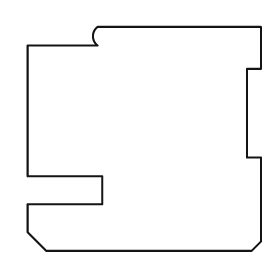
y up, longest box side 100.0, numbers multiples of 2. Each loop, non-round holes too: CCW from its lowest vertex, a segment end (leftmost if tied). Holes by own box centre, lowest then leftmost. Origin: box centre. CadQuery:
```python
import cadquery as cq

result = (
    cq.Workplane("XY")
    .moveTo(-42.0, -48.0)
    .lineTo(46.0, -48.0)
    .lineTo(50.0, -44.0)
    .lineTo(50.0, -8.0)
    .lineTo(44.0, -8.0)
    .lineTo(44.0, 30.0)
    .lineTo(50.0, 30.0)
    .lineTo(50.0, 48.0)
    .lineTo(-20.0, 48.0)
    .threePointArc((-22.0, 44.0), (-20.0, 40.0))
    .lineTo(-50.0, 40.0)
    .lineTo(-50.0, -16.0)
    .lineTo(-18.0, -16.0)
    .lineTo(-18.0, -28.0)
    .lineTo(-50.0, -28.0)
    .lineTo(-50.0, -40.0)
    .close()
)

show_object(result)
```